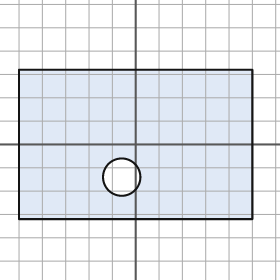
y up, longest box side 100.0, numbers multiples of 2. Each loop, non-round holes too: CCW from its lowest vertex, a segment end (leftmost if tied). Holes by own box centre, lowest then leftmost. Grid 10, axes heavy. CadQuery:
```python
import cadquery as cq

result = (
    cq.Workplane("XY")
    .moveTo(-50.0, -32.0)
    .lineTo(50.0, -32.0)
    .lineTo(50.0, 32.0)
    .lineTo(-50.0, 32.0)
    .close()
    .moveTo(-6.0, -14.0)
    .circle(8.0)
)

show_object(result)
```